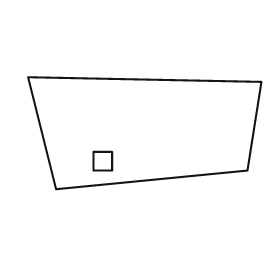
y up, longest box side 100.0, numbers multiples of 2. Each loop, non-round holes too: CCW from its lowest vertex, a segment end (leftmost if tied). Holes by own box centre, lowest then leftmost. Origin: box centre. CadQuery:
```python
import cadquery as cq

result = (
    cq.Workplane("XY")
    .moveTo(-38.0, -24.0)
    .lineTo(44.0, -16.0)
    .lineTo(50.0, 22.0)
    .lineTo(-50.0, 24.0)
    .close()
    .moveTo(-22.0, -16.0)
    .lineTo(-14.0, -16.0)
    .lineTo(-14.0, -8.0)
    .lineTo(-22.0, -8.0)
    .close()
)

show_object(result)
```